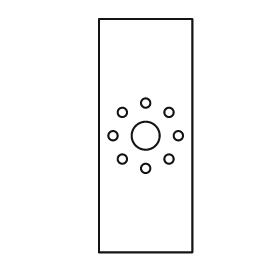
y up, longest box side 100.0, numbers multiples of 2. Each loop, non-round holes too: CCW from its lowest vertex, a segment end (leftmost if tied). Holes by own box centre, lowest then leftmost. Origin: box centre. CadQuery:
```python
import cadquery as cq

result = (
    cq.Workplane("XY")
    .moveTo(-20.0, -50.0)
    .lineTo(20.0, -50.0)
    .lineTo(20.0, 50.0)
    .lineTo(-20.0, 50.0)
    .close()
    .moveTo(0.0, -14.0)
    .circle(2.0)
    .moveTo(-10.0, -10.0)
    .circle(2.0)
    .moveTo(10.0, -10.0)
    .circle(2.0)
    .moveTo(-14.0, 0.0)
    .circle(2.0)
    .moveTo(0.0, 0.0)
    .circle(6.0)
    .moveTo(14.0, 0.0)
    .circle(2.0)
    .moveTo(-10.0, 10.0)
    .circle(2.0)
    .moveTo(10.0, 10.0)
    .circle(2.0)
    .moveTo(0.0, 14.0)
    .circle(2.0)
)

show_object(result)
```